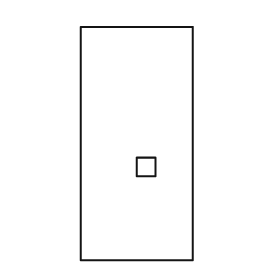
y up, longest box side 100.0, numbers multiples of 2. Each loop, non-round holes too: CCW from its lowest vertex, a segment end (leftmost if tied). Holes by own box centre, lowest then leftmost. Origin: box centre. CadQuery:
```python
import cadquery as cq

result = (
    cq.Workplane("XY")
    .moveTo(-24.0, -50.0)
    .lineTo(24.0, -50.0)
    .lineTo(24.0, 50.0)
    .lineTo(-24.0, 50.0)
    .close()
    .moveTo(0.0, -14.0)
    .lineTo(8.0, -14.0)
    .lineTo(8.0, -6.0)
    .lineTo(0.0, -6.0)
    .close()
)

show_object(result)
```